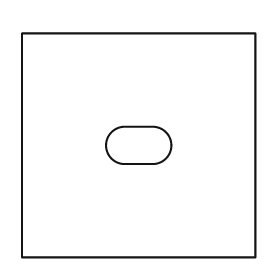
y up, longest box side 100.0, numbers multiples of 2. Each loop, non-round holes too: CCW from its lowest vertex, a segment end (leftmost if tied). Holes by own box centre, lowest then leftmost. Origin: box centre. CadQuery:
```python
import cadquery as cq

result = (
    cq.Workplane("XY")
    .moveTo(-50.0, -48.0)
    .lineTo(50.0, -48.0)
    .lineTo(50.0, 48.0)
    .lineTo(-50.0, 48.0)
    .close()
    .moveTo(-6.0, -8.0)
    .lineTo(6.0, -8.0)
    .threePointArc((14.0, 0.0), (6.0, 8.0))
    .lineTo(-6.0, 8.0)
    .threePointArc((-14.0, 0.0), (-6.0, -8.0))
    .close()
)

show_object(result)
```